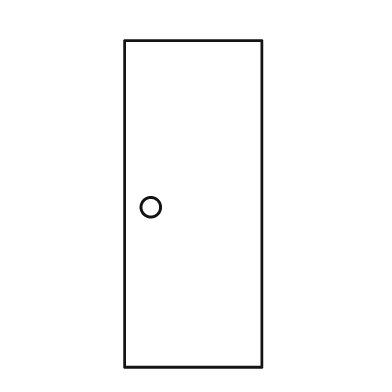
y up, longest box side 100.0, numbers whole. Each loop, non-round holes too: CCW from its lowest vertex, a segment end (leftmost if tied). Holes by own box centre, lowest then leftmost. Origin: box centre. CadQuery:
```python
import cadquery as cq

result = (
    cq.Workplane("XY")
    .moveTo(-21.0, -50.0)
    .lineTo(21.0, -50.0)
    .lineTo(21.0, 50.0)
    .lineTo(-21.0, 50.0)
    .close()
    .moveTo(-13.0, -1.0)
    .circle(3.0)
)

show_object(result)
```